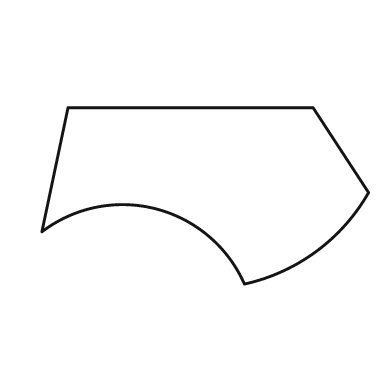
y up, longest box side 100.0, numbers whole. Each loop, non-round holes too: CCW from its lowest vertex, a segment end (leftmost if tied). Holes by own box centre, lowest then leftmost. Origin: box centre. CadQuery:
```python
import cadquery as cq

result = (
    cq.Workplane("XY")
    .moveTo(12.0, -27.0)
    .threePointArc((34.0, -17.0), (50.0, 1.0))
    .lineTo(33.0, 27.0)
    .lineTo(-42.0, 27.0)
    .lineTo(-50.0, -11.0)
    .threePointArc((-15.0, -4.0), (12.0, -27.0))
    .close()
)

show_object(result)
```